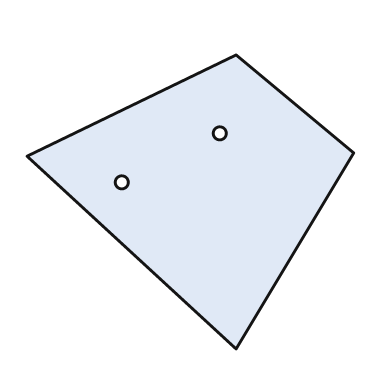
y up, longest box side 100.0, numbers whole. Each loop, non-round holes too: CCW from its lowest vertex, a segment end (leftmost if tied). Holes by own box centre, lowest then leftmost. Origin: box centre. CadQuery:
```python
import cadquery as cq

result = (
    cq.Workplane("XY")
    .moveTo(14.0, -45.0)
    .lineTo(50.0, 15.0)
    .lineTo(14.0, 45.0)
    .lineTo(-50.0, 14.0)
    .close()
    .moveTo(-21.0, 6.0)
    .circle(2.0)
    .moveTo(9.0, 21.0)
    .circle(2.0)
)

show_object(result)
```